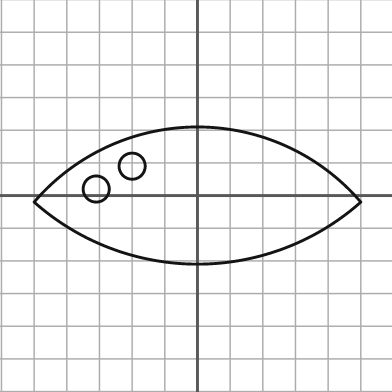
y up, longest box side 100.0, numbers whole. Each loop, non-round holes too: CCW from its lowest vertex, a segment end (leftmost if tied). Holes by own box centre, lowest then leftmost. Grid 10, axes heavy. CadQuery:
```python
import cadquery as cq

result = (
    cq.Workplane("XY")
    .moveTo(-50.0, -2.0)
    .threePointArc((0.0, -21.0), (50.0, -2.0))
    .threePointArc((0.0, 21.0), (-50.0, -2.0))
    .close()
    .moveTo(-31.0, 2.0)
    .circle(4.0)
    .moveTo(-20.0, 9.0)
    .circle(4.0)
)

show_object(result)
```